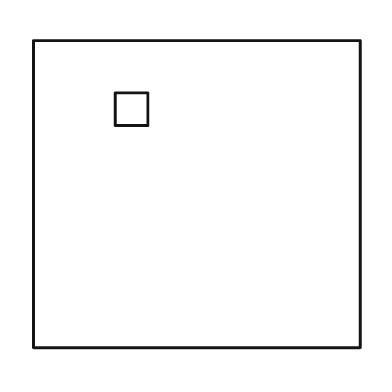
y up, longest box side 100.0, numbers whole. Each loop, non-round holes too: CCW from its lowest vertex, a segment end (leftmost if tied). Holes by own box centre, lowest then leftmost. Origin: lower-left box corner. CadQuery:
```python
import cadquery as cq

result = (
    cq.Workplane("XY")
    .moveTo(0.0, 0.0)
    .lineTo(100.0, 0.0)
    .lineTo(100.0, 94.0)
    .lineTo(0.0, 94.0)
    .close()
    .moveTo(25.0, 68.0)
    .lineTo(35.0, 68.0)
    .lineTo(35.0, 78.0)
    .lineTo(25.0, 78.0)
    .close()
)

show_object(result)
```